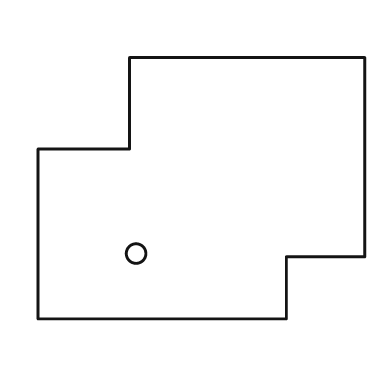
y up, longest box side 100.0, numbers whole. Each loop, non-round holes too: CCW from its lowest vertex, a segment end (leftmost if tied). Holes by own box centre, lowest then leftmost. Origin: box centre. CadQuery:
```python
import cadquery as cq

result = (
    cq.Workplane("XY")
    .moveTo(-50.0, -40.0)
    .lineTo(26.0, -40.0)
    .lineTo(26.0, -21.0)
    .lineTo(50.0, -21.0)
    .lineTo(50.0, 40.0)
    .lineTo(-22.0, 40.0)
    .lineTo(-22.0, 12.0)
    .lineTo(-50.0, 12.0)
    .close()
    .moveTo(-20.0, -20.0)
    .circle(3.0)
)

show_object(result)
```